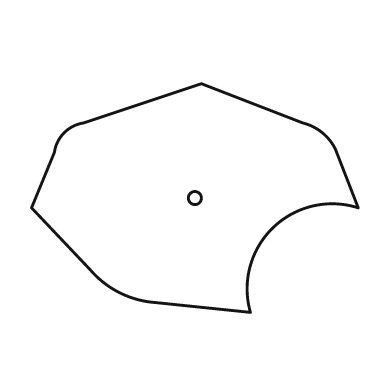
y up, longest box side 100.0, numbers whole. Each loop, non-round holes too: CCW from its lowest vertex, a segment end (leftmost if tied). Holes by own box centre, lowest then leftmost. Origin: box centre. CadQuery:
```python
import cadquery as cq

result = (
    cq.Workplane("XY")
    .moveTo(17.0, -35.0)
    .threePointArc((24.0, -9.0), (50.0, -3.0))
    .lineTo(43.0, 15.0)
    .threePointArc((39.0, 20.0), (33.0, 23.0))
    .lineTo(2.0, 35.0)
    .lineTo(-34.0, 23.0)
    .threePointArc((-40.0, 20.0), (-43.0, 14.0))
    .lineTo(-50.0, -3.0)
    .lineTo(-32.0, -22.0)
    .threePointArc((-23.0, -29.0), (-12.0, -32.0))
    .close()
    .moveTo(0.0, 0.0)
    .circle(2.0)
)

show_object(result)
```